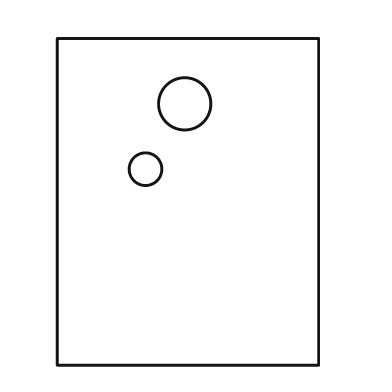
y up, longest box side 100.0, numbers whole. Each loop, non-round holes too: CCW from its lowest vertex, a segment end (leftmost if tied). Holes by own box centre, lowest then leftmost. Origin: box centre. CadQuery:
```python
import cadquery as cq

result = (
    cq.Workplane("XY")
    .moveTo(-40.0, -50.0)
    .lineTo(40.0, -50.0)
    .lineTo(40.0, 50.0)
    .lineTo(-40.0, 50.0)
    .close()
    .moveTo(-13.0, 10.0)
    .circle(5.0)
    .moveTo(-1.0, 30.0)
    .circle(8.0)
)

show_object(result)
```